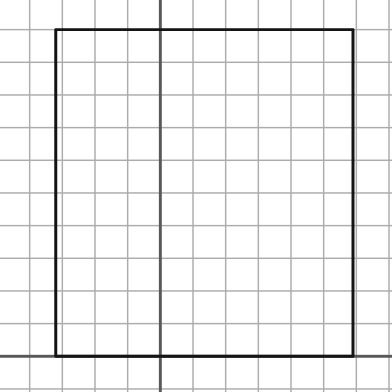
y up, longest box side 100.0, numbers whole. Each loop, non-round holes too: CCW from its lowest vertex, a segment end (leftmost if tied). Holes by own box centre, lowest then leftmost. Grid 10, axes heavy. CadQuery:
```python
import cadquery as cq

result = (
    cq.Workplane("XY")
    .moveTo(-32.0, 0.0)
    .lineTo(59.0, 0.0)
    .lineTo(59.0, 100.0)
    .lineTo(-32.0, 100.0)
    .close()
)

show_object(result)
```